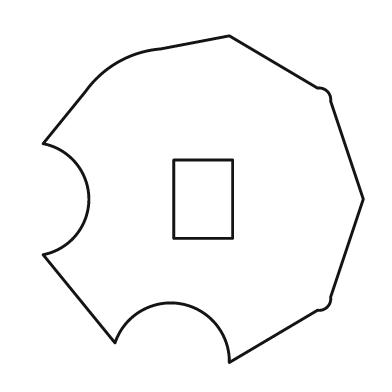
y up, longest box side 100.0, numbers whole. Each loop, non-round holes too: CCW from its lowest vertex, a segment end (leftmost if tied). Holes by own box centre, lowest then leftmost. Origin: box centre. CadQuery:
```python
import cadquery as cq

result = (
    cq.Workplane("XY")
    .moveTo(8.0, -50.0)
    .lineTo(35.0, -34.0)
    .threePointArc((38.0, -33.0), (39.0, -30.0))
    .lineTo(49.0, 0.0)
    .lineTo(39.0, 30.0)
    .threePointArc((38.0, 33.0), (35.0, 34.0))
    .lineTo(8.0, 50.0)
    .lineTo(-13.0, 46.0)
    .threePointArc((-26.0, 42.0), (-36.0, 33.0))
    .lineTo(-49.0, 17.0)
    .threePointArc((-35.0, 0.0), (-49.0, -17.0))
    .lineTo(-27.0, -44.0)
    .threePointArc((-7.0, -32.0), (8.0, -50.0))
    .close()
    .moveTo(-9.0, -12.0)
    .lineTo(9.0, -12.0)
    .lineTo(9.0, 12.0)
    .lineTo(-9.0, 12.0)
    .close()
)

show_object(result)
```